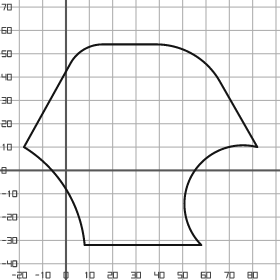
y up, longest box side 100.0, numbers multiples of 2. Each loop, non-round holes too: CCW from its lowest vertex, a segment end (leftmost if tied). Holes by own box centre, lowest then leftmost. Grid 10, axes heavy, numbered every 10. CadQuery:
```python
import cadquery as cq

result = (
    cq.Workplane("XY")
    .moveTo(8.0, -32.0)
    .lineTo(58.0, -32.0)
    .threePointArc((54.0, -2.0), (82.0, 10.0))
    .lineTo(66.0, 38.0)
    .threePointArc((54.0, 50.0), (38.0, 54.0))
    .lineTo(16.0, 54.0)
    .threePointArc((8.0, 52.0), (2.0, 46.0))
    .lineTo(-18.0, 10.0)
    .threePointArc((0.0, -8.0), (8.0, -32.0))
    .close()
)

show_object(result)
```